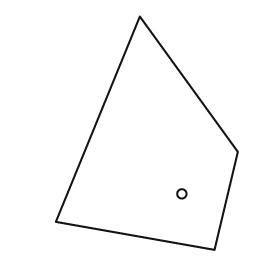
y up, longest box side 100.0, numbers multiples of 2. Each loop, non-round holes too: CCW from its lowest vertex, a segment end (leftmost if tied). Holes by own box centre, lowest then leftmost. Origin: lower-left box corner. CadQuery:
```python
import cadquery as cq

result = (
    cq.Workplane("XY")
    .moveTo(68.0, 0.0)
    .lineTo(78.0, 42.0)
    .lineTo(36.0, 100.0)
    .lineTo(0.0, 12.0)
    .close()
    .moveTo(54.0, 24.0)
    .circle(2.0)
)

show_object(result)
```